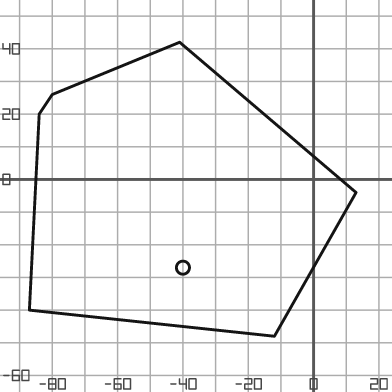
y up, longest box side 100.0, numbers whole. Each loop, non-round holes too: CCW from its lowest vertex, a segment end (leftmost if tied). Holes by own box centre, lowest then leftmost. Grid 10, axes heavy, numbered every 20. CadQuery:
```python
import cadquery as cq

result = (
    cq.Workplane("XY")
    .moveTo(-12.0, -48.0)
    .lineTo(13.0, -4.0)
    .lineTo(-41.0, 42.0)
    .lineTo(-80.0, 26.0)
    .lineTo(-84.0, 20.0)
    .lineTo(-87.0, -40.0)
    .close()
    .moveTo(-40.0, -27.0)
    .circle(2.0)
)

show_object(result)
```